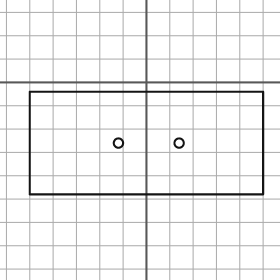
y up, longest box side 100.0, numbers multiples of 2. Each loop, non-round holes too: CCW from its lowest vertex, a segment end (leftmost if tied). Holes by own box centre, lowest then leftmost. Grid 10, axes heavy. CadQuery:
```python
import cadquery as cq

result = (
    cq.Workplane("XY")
    .moveTo(-50.0, -48.0)
    .lineTo(50.0, -48.0)
    .lineTo(50.0, -4.0)
    .lineTo(-50.0, -4.0)
    .close()
    .moveTo(-12.0, -26.0)
    .circle(2.0)
    .moveTo(14.0, -26.0)
    .circle(2.0)
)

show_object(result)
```